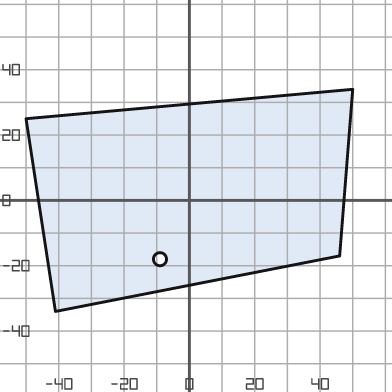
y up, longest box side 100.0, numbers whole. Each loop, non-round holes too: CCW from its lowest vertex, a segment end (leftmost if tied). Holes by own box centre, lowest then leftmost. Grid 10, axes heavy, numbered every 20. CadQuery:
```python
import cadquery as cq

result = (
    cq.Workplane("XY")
    .moveTo(-41.0, -34.0)
    .lineTo(46.0, -17.0)
    .lineTo(50.0, 34.0)
    .lineTo(-50.0, 25.0)
    .close()
    .moveTo(-9.0, -18.0)
    .circle(2.0)
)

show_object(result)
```